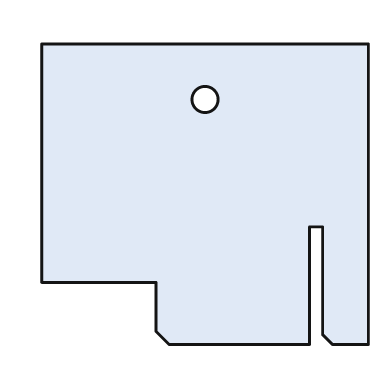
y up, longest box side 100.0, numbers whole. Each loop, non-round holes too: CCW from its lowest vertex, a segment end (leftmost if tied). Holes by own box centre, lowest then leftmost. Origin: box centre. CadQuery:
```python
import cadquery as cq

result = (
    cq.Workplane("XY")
    .moveTo(-11.0, -46.0)
    .lineTo(32.0, -46.0)
    .lineTo(32.0, -10.0)
    .lineTo(36.0, -10.0)
    .lineTo(36.0, -43.0)
    .lineTo(39.0, -46.0)
    .lineTo(50.0, -46.0)
    .lineTo(50.0, 46.0)
    .lineTo(-50.0, 46.0)
    .lineTo(-50.0, -27.0)
    .lineTo(-15.0, -27.0)
    .lineTo(-15.0, -42.0)
    .close()
    .moveTo(0.0, 29.0)
    .circle(4.0)
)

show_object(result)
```